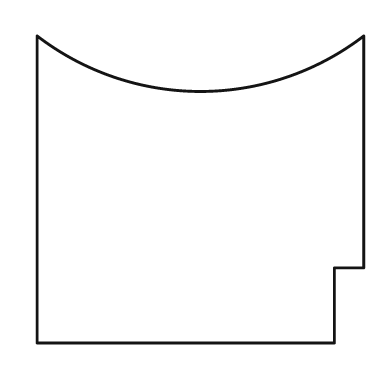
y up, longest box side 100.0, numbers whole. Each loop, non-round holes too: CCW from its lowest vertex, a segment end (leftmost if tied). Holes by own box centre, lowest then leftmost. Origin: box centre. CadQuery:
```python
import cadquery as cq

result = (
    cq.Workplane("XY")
    .moveTo(-50.0, -47.0)
    .lineTo(41.0, -47.0)
    .lineTo(41.0, -24.0)
    .lineTo(50.0, -24.0)
    .lineTo(50.0, 47.0)
    .threePointArc((0.0, 30.0), (-50.0, 47.0))
    .close()
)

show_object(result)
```